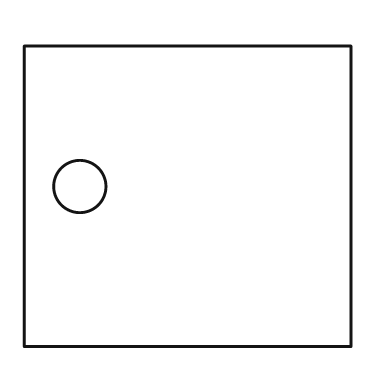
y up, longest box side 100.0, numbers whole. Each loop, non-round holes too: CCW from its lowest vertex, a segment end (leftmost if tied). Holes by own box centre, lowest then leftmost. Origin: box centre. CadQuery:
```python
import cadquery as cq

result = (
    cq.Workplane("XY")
    .moveTo(-50.0, -46.0)
    .lineTo(50.0, -46.0)
    .lineTo(50.0, 46.0)
    .lineTo(-50.0, 46.0)
    .close()
    .moveTo(-33.0, 3.0)
    .circle(8.0)
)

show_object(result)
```